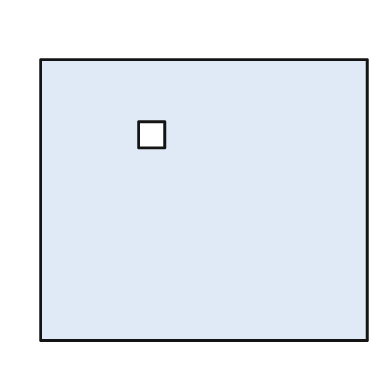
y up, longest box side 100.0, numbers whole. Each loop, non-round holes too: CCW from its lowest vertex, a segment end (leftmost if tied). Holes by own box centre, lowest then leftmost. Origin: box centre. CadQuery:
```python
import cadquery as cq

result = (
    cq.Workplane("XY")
    .moveTo(-50.0, -43.0)
    .lineTo(50.0, -43.0)
    .lineTo(50.0, 43.0)
    .lineTo(-50.0, 43.0)
    .close()
    .moveTo(-20.0, 16.0)
    .lineTo(-12.0, 16.0)
    .lineTo(-12.0, 24.0)
    .lineTo(-20.0, 24.0)
    .close()
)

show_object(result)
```